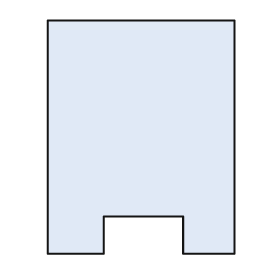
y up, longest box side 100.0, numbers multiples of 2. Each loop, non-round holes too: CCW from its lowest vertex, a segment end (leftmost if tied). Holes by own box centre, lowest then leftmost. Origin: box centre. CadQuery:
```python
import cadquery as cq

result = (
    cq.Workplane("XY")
    .moveTo(-40.0, -50.0)
    .lineTo(-16.0, -50.0)
    .lineTo(-16.0, -34.0)
    .lineTo(18.0, -34.0)
    .lineTo(18.0, -50.0)
    .lineTo(40.0, -50.0)
    .lineTo(40.0, 50.0)
    .lineTo(-40.0, 50.0)
    .close()
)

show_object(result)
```